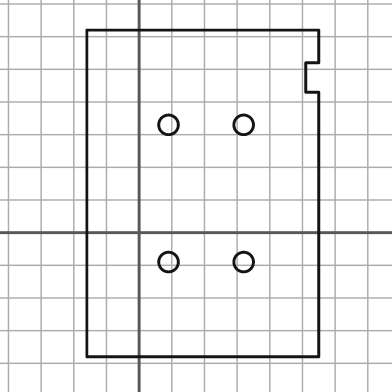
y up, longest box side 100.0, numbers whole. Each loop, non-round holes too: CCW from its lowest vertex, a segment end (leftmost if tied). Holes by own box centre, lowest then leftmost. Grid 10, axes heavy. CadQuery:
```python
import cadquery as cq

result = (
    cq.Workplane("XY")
    .moveTo(-16.0, -38.0)
    .lineTo(55.0, -38.0)
    .lineTo(55.0, 43.0)
    .lineTo(51.0, 43.0)
    .lineTo(51.0, 52.0)
    .lineTo(55.0, 52.0)
    .lineTo(55.0, 62.0)
    .lineTo(-16.0, 62.0)
    .close()
    .moveTo(9.0, -9.0)
    .circle(3.0)
    .moveTo(32.0, -9.0)
    .circle(3.0)
    .moveTo(9.0, 33.0)
    .circle(3.0)
    .moveTo(32.0, 33.0)
    .circle(3.0)
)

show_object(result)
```